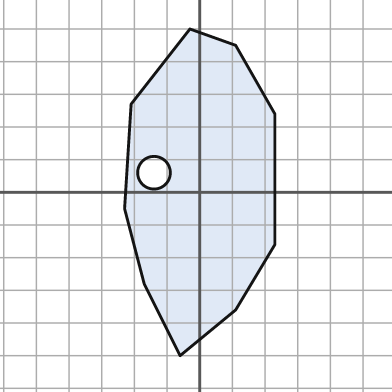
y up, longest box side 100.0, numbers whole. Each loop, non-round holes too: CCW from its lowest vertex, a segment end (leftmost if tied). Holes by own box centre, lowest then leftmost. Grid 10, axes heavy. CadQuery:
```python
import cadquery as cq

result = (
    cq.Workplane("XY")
    .moveTo(-6.0, -50.0)
    .lineTo(11.0, -36.0)
    .lineTo(23.0, -16.0)
    .lineTo(23.0, 24.0)
    .lineTo(11.0, 45.0)
    .lineTo(-3.0, 50.0)
    .lineTo(-21.0, 27.0)
    .lineTo(-23.0, -5.0)
    .lineTo(-17.0, -28.0)
    .close()
    .moveTo(-14.0, 6.0)
    .circle(5.0)
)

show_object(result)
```